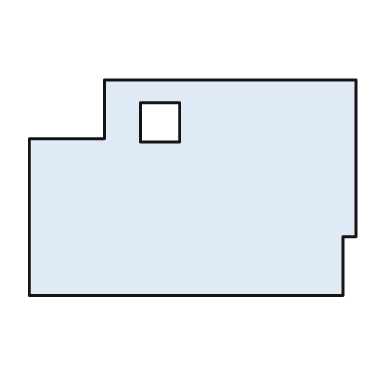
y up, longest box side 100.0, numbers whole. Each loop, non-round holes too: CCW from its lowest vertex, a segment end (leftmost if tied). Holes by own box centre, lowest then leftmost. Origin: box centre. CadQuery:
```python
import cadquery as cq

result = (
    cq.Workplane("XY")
    .moveTo(-50.0, -33.0)
    .lineTo(46.0, -33.0)
    .lineTo(46.0, -15.0)
    .lineTo(50.0, -15.0)
    .lineTo(50.0, 33.0)
    .lineTo(-27.0, 33.0)
    .lineTo(-27.0, 15.0)
    .lineTo(-50.0, 15.0)
    .close()
    .moveTo(-16.0, 14.0)
    .lineTo(-4.0, 14.0)
    .lineTo(-4.0, 26.0)
    .lineTo(-16.0, 26.0)
    .close()
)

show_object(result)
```